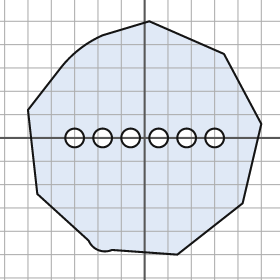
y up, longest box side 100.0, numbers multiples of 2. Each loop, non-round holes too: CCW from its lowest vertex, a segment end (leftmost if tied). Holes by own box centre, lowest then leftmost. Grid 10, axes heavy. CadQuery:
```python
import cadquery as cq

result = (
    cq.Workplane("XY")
    .moveTo(14.0, -50.0)
    .lineTo(42.0, -28.0)
    .lineTo(50.0, 6.0)
    .lineTo(34.0, 36.0)
    .lineTo(2.0, 50.0)
    .lineTo(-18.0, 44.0)
    .threePointArc((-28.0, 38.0), (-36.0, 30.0))
    .lineTo(-50.0, 12.0)
    .lineTo(-46.0, -24.0)
    .lineTo(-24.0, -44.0)
    .threePointArc((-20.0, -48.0), (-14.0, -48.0))
    .close()
    .moveTo(-30.0, 0.0)
    .circle(4.0)
    .moveTo(-18.0, 0.0)
    .circle(4.0)
    .moveTo(-6.0, 0.0)
    .circle(4.0)
    .moveTo(6.0, 0.0)
    .circle(4.0)
    .moveTo(18.0, 0.0)
    .circle(4.0)
    .moveTo(30.0, 0.0)
    .circle(4.0)
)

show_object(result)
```